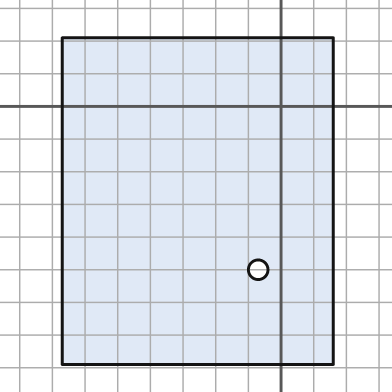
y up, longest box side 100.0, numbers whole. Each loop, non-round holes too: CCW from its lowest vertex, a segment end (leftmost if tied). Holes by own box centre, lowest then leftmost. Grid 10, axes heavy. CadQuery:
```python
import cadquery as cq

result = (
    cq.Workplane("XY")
    .moveTo(-67.0, -79.0)
    .lineTo(16.0, -79.0)
    .lineTo(16.0, 21.0)
    .lineTo(-67.0, 21.0)
    .close()
    .moveTo(-7.0, -50.0)
    .circle(3.0)
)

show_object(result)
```